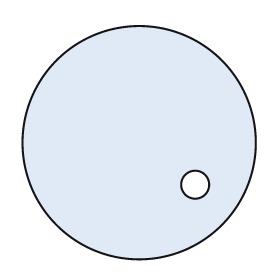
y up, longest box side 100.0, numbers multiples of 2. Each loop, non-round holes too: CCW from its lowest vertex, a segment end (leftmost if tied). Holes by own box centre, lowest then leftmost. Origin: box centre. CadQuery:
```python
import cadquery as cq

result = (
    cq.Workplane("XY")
    .moveTo(0.0, 0.0)
    .circle(50.0)
    .moveTo(24.0, -18.0)
    .circle(6.0)
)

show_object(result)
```